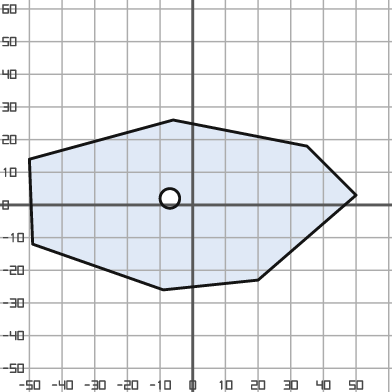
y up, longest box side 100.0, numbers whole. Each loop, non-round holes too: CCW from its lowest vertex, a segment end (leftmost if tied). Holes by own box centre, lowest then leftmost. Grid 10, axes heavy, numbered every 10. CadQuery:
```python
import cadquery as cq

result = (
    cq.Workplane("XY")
    .moveTo(-9.0, -26.0)
    .lineTo(20.0, -23.0)
    .lineTo(50.0, 3.0)
    .lineTo(35.0, 18.0)
    .lineTo(-6.0, 26.0)
    .lineTo(-50.0, 14.0)
    .lineTo(-49.0, -12.0)
    .close()
    .moveTo(-7.0, 2.0)
    .circle(3.0)
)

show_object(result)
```